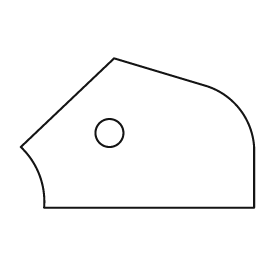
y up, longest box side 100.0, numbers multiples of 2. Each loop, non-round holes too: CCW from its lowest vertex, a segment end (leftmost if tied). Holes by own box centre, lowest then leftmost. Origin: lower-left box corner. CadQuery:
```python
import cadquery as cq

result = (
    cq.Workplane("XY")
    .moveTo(10.0, 0.0)
    .lineTo(100.0, 0.0)
    .lineTo(100.0, 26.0)
    .threePointArc((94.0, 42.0), (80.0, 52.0))
    .lineTo(40.0, 64.0)
    .lineTo(0.0, 26.0)
    .threePointArc((8.0, 14.0), (10.0, 0.0))
    .close()
    .moveTo(38.0, 32.0)
    .circle(6.0)
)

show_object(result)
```